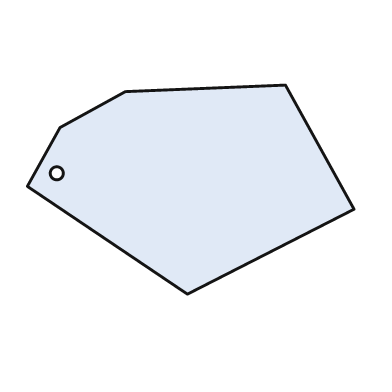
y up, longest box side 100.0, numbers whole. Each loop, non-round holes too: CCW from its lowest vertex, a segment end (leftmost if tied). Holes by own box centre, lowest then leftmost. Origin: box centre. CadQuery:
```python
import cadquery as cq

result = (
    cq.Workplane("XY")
    .moveTo(-1.0, -32.0)
    .lineTo(50.0, -6.0)
    .lineTo(29.0, 32.0)
    .lineTo(-20.0, 30.0)
    .lineTo(-40.0, 19.0)
    .lineTo(-50.0, 1.0)
    .close()
    .moveTo(-41.0, 5.0)
    .circle(2.0)
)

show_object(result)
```